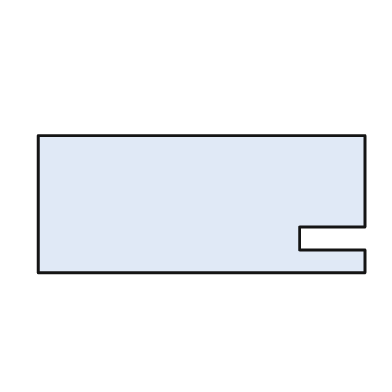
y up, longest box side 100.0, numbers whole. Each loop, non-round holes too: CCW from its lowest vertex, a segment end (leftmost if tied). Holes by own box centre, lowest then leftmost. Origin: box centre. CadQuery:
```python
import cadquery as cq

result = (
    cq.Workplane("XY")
    .moveTo(-50.0, -21.0)
    .lineTo(50.0, -21.0)
    .lineTo(50.0, -14.0)
    .lineTo(30.0, -14.0)
    .lineTo(30.0, -7.0)
    .lineTo(50.0, -7.0)
    .lineTo(50.0, 21.0)
    .lineTo(-50.0, 21.0)
    .close()
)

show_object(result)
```